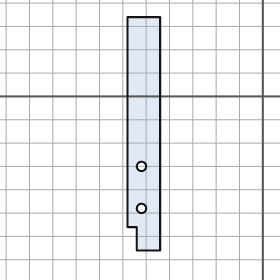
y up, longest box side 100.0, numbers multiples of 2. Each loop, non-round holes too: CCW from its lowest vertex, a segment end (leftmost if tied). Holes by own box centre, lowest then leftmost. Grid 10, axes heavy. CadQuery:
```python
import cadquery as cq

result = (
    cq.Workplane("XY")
    .moveTo(-54.0, -66.0)
    .lineTo(-44.0, -66.0)
    .lineTo(-44.0, 34.0)
    .lineTo(-58.0, 34.0)
    .lineTo(-58.0, -56.0)
    .lineTo(-54.0, -56.0)
    .close()
    .moveTo(-52.0, -48.0)
    .circle(2.0)
    .moveTo(-52.0, -30.0)
    .circle(2.0)
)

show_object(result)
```